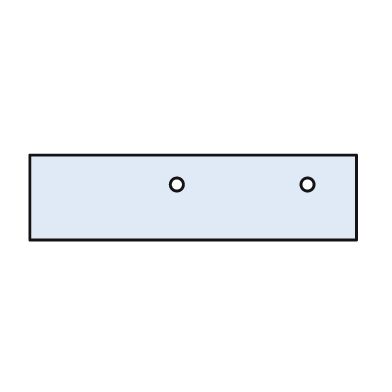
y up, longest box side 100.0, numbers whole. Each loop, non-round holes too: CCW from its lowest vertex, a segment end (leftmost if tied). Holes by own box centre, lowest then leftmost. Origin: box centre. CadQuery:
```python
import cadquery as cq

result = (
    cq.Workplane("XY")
    .moveTo(-50.0, -13.0)
    .lineTo(50.0, -13.0)
    .lineTo(50.0, 13.0)
    .lineTo(-50.0, 13.0)
    .close()
    .moveTo(-5.0, 4.0)
    .circle(2.0)
    .moveTo(35.0, 4.0)
    .circle(2.0)
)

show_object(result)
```